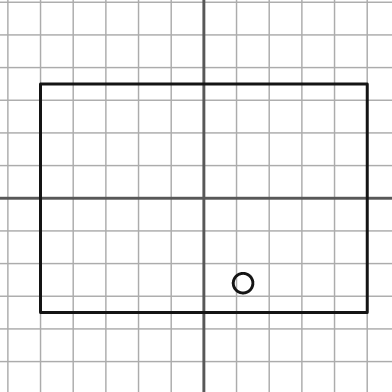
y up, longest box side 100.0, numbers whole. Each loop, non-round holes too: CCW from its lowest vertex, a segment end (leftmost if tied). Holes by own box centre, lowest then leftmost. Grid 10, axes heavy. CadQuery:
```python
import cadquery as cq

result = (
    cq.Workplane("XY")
    .moveTo(-50.0, -35.0)
    .lineTo(50.0, -35.0)
    .lineTo(50.0, 35.0)
    .lineTo(-50.0, 35.0)
    .close()
    .moveTo(12.0, -26.0)
    .circle(3.0)
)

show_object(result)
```